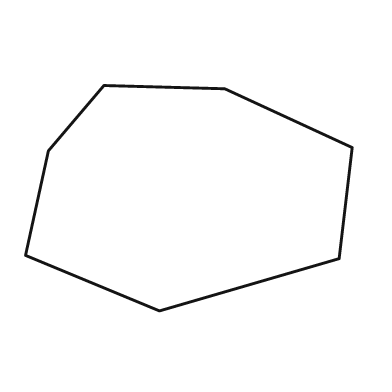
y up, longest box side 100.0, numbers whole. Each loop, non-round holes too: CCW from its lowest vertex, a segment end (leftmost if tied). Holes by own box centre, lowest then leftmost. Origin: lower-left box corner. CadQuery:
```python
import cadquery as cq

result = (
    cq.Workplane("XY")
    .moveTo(41.0, 0.0)
    .lineTo(96.0, 16.0)
    .lineTo(100.0, 50.0)
    .lineTo(61.0, 68.0)
    .lineTo(24.0, 69.0)
    .lineTo(7.0, 49.0)
    .lineTo(0.0, 17.0)
    .close()
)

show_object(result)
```